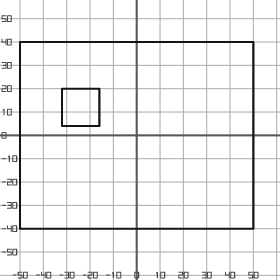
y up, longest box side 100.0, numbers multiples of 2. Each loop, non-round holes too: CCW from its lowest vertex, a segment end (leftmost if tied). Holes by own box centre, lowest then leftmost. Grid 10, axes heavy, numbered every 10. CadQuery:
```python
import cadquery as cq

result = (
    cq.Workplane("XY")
    .moveTo(-50.0, -40.0)
    .lineTo(50.0, -40.0)
    .lineTo(50.0, 40.0)
    .lineTo(-50.0, 40.0)
    .close()
    .moveTo(-32.0, 4.0)
    .lineTo(-16.0, 4.0)
    .lineTo(-16.0, 20.0)
    .lineTo(-32.0, 20.0)
    .close()
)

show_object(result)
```